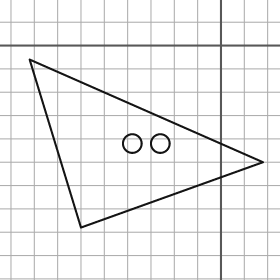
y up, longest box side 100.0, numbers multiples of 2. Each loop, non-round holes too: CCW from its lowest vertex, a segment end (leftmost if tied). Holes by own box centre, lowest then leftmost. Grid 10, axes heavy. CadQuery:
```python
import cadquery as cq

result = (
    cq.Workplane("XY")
    .moveTo(-60.0, -78.0)
    .lineTo(18.0, -50.0)
    .lineTo(-82.0, -6.0)
    .close()
    .moveTo(-38.0, -42.0)
    .circle(4.0)
    .moveTo(-26.0, -42.0)
    .circle(4.0)
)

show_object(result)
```